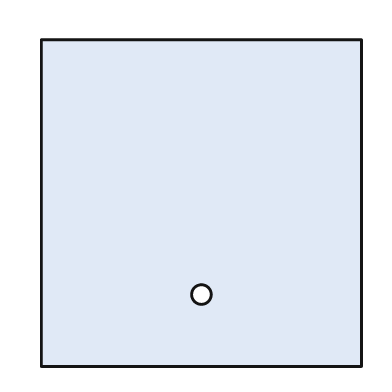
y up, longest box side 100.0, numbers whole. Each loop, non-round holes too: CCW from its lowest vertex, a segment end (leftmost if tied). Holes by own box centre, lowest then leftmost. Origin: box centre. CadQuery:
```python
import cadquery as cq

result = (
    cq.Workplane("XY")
    .moveTo(-49.0, -50.0)
    .lineTo(49.0, -50.0)
    .lineTo(49.0, 50.0)
    .lineTo(-49.0, 50.0)
    .close()
    .moveTo(0.0, -28.0)
    .circle(3.0)
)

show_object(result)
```